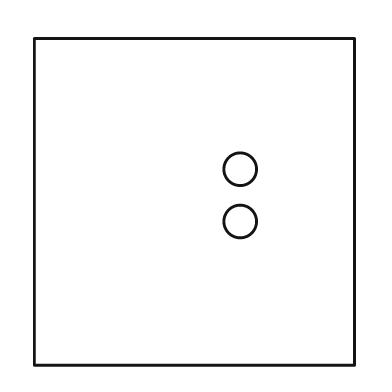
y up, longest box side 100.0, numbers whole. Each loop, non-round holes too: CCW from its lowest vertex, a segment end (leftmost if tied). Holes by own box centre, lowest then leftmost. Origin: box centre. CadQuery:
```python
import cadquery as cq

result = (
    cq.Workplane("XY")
    .moveTo(-49.0, -50.0)
    .lineTo(49.0, -50.0)
    .lineTo(49.0, 50.0)
    .lineTo(-49.0, 50.0)
    .close()
    .moveTo(14.0, -6.0)
    .circle(5.0)
    .moveTo(14.0, 10.0)
    .circle(5.0)
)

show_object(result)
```